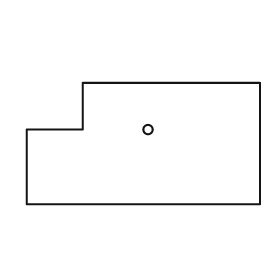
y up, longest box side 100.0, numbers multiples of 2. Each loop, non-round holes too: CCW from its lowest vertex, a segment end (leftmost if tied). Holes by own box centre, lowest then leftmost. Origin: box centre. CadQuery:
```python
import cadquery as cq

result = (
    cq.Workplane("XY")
    .moveTo(-50.0, -26.0)
    .lineTo(50.0, -26.0)
    .lineTo(50.0, 26.0)
    .lineTo(-26.0, 26.0)
    .lineTo(-26.0, 6.0)
    .lineTo(-50.0, 6.0)
    .close()
    .moveTo(2.0, 6.0)
    .circle(2.0)
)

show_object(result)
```